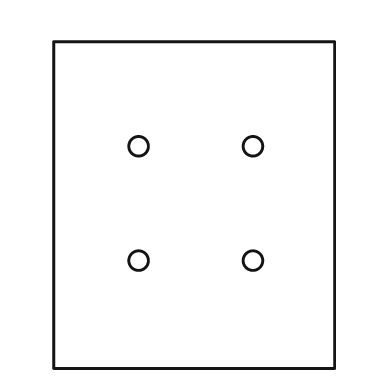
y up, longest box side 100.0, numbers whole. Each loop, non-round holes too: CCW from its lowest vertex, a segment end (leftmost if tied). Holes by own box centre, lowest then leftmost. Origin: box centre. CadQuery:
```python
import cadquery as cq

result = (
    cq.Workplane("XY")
    .moveTo(-43.0, -50.0)
    .lineTo(43.0, -50.0)
    .lineTo(43.0, 50.0)
    .lineTo(-43.0, 50.0)
    .close()
    .moveTo(-17.0, -17.0)
    .circle(3.0)
    .moveTo(18.0, -17.0)
    .circle(3.0)
    .moveTo(-17.0, 18.0)
    .circle(3.0)
    .moveTo(18.0, 18.0)
    .circle(3.0)
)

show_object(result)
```